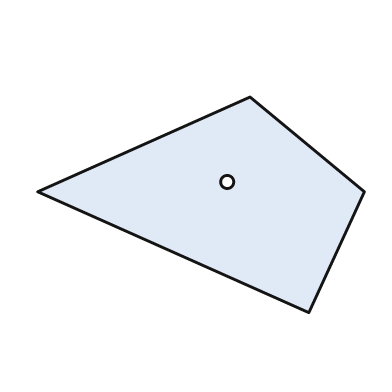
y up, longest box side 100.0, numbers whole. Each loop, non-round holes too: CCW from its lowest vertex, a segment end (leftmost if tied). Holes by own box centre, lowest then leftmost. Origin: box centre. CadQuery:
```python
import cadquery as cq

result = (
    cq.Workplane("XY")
    .moveTo(33.0, -33.0)
    .lineTo(50.0, 4.0)
    .lineTo(15.0, 33.0)
    .lineTo(-50.0, 4.0)
    .close()
    .moveTo(8.0, 7.0)
    .circle(2.0)
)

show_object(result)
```